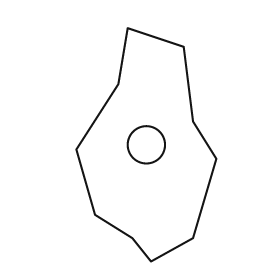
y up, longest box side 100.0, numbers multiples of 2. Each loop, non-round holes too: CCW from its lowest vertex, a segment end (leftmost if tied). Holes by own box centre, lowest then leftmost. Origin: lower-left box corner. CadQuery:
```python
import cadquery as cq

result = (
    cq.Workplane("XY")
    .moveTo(32.0, 0.0)
    .lineTo(50.0, 10.0)
    .lineTo(60.0, 44.0)
    .lineTo(50.0, 60.0)
    .lineTo(46.0, 92.0)
    .lineTo(22.0, 100.0)
    .lineTo(18.0, 76.0)
    .lineTo(0.0, 48.0)
    .lineTo(8.0, 20.0)
    .lineTo(24.0, 10.0)
    .close()
    .moveTo(30.0, 50.0)
    .circle(8.0)
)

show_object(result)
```